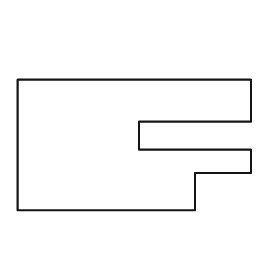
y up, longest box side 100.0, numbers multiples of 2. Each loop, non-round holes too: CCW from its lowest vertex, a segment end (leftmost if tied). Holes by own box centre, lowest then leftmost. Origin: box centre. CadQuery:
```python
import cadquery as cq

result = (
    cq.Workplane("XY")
    .moveTo(-50.0, -28.0)
    .lineTo(26.0, -28.0)
    .lineTo(26.0, -12.0)
    .lineTo(50.0, -12.0)
    .lineTo(50.0, -2.0)
    .lineTo(2.0, -2.0)
    .lineTo(2.0, 10.0)
    .lineTo(50.0, 10.0)
    .lineTo(50.0, 28.0)
    .lineTo(-50.0, 28.0)
    .close()
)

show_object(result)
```